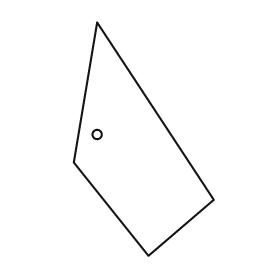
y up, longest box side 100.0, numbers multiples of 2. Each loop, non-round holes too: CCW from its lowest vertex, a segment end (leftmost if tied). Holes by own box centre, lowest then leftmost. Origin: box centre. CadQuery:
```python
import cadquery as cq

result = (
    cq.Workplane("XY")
    .moveTo(2.0, -50.0)
    .lineTo(30.0, -26.0)
    .lineTo(-20.0, 50.0)
    .lineTo(-30.0, -10.0)
    .close()
    .moveTo(-20.0, 2.0)
    .circle(2.0)
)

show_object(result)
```